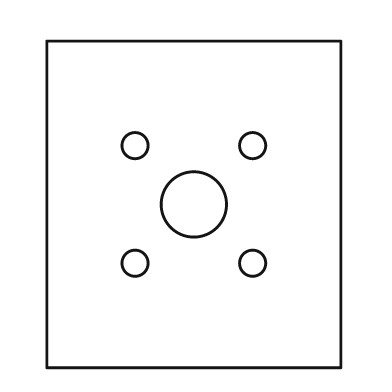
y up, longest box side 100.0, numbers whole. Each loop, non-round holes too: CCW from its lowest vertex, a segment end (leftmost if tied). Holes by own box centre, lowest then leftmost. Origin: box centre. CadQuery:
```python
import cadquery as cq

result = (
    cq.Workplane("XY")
    .moveTo(-45.0, -50.0)
    .lineTo(45.0, -50.0)
    .lineTo(45.0, 50.0)
    .lineTo(-45.0, 50.0)
    .close()
    .moveTo(-18.0, -18.0)
    .circle(4.0)
    .moveTo(18.0, -18.0)
    .circle(4.0)
    .moveTo(0.0, 0.0)
    .circle(10.0)
    .moveTo(-18.0, 18.0)
    .circle(4.0)
    .moveTo(18.0, 18.0)
    .circle(4.0)
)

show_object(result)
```